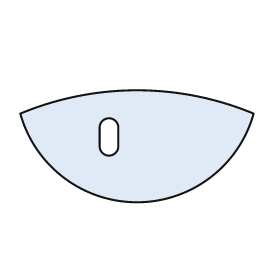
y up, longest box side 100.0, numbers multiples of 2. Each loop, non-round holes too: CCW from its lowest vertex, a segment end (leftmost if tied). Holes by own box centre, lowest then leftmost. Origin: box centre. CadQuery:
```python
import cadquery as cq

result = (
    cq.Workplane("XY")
    .moveTo(-50.0, 14.0)
    .threePointArc((0.0, -24.0), (50.0, 14.0))
    .threePointArc((0.0, 24.0), (-50.0, 14.0))
    .close()
    .moveTo(-16.0, 0.0)
    .threePointArc((-12.0, -4.0), (-8.0, 0.0))
    .lineTo(-8.0, 8.0)
    .threePointArc((-12.0, 12.0), (-16.0, 8.0))
    .close()
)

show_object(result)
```